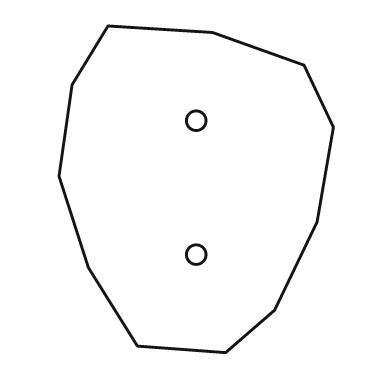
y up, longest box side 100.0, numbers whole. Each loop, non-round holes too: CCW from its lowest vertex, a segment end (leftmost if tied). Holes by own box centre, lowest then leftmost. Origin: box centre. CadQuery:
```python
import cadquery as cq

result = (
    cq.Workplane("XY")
    .moveTo(9.0, -50.0)
    .lineTo(24.0, -37.0)
    .lineTo(37.0, -10.0)
    .lineTo(42.0, 19.0)
    .lineTo(33.0, 38.0)
    .lineTo(5.0, 48.0)
    .lineTo(-27.0, 50.0)
    .lineTo(-38.0, 32.0)
    .lineTo(-42.0, 4.0)
    .lineTo(-33.0, -24.0)
    .lineTo(-18.0, -48.0)
    .close()
    .moveTo(0.0, -20.0)
    .circle(3.0)
    .moveTo(0.0, 21.0)
    .circle(3.0)
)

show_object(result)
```